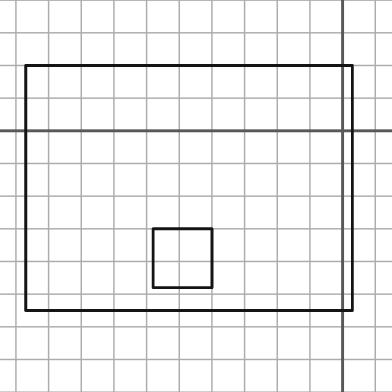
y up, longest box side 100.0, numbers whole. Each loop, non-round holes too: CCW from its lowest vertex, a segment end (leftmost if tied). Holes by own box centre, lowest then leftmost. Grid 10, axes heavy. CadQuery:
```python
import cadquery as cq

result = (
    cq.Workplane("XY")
    .moveTo(-97.0, -55.0)
    .lineTo(3.0, -55.0)
    .lineTo(3.0, 20.0)
    .lineTo(-97.0, 20.0)
    .close()
    .moveTo(-58.0, -48.0)
    .lineTo(-40.0, -48.0)
    .lineTo(-40.0, -30.0)
    .lineTo(-58.0, -30.0)
    .close()
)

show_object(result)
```